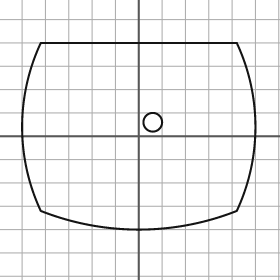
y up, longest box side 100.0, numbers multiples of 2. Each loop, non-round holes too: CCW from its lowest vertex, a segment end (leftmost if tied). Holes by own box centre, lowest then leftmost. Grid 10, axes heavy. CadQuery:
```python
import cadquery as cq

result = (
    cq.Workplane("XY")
    .moveTo(-42.0, -32.0)
    .threePointArc((0.0, -40.0), (42.0, -32.0))
    .threePointArc((50.0, 4.0), (42.0, 40.0))
    .lineTo(-42.0, 40.0)
    .threePointArc((-50.0, 4.0), (-42.0, -32.0))
    .close()
    .moveTo(6.0, 6.0)
    .circle(4.0)
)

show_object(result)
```